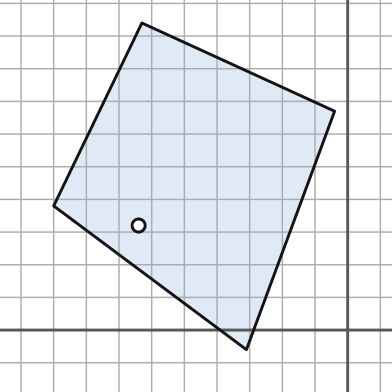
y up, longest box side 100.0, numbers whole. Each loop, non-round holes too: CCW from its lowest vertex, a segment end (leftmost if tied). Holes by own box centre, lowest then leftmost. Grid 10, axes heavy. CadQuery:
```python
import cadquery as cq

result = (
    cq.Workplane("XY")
    .moveTo(-31.0, -6.0)
    .lineTo(-4.0, 67.0)
    .lineTo(-63.0, 94.0)
    .lineTo(-90.0, 38.0)
    .close()
    .moveTo(-64.0, 32.0)
    .circle(2.0)
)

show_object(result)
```